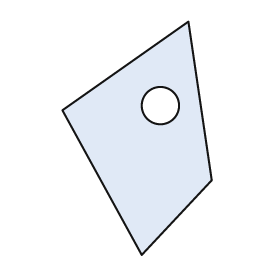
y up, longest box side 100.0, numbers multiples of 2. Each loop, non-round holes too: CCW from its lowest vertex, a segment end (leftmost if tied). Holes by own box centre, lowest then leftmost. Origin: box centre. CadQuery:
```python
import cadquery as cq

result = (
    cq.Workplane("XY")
    .moveTo(2.0, -50.0)
    .lineTo(32.0, -18.0)
    .lineTo(22.0, 50.0)
    .lineTo(-32.0, 12.0)
    .close()
    .moveTo(10.0, 14.0)
    .circle(8.0)
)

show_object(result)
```